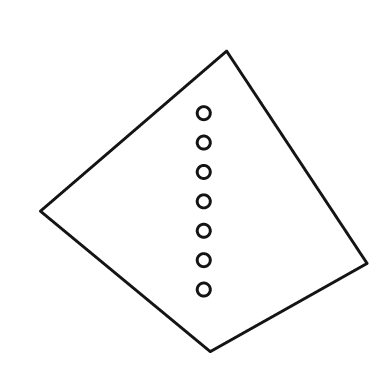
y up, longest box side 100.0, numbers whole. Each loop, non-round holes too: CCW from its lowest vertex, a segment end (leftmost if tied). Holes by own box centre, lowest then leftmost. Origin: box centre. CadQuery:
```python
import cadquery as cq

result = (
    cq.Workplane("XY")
    .moveTo(2.0, -46.0)
    .lineTo(50.0, -19.0)
    .lineTo(7.0, 46.0)
    .lineTo(-50.0, -3.0)
    .close()
    .moveTo(0.0, -27.0)
    .circle(2.0)
    .moveTo(0.0, -18.0)
    .circle(2.0)
    .moveTo(0.0, -9.0)
    .circle(2.0)
    .moveTo(0.0, 0.0)
    .circle(2.0)
    .moveTo(0.0, 9.0)
    .circle(2.0)
    .moveTo(0.0, 18.0)
    .circle(2.0)
    .moveTo(0.0, 27.0)
    .circle(2.0)
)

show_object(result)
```